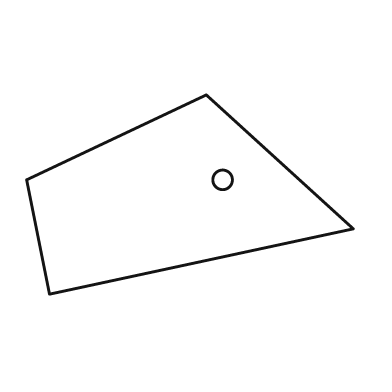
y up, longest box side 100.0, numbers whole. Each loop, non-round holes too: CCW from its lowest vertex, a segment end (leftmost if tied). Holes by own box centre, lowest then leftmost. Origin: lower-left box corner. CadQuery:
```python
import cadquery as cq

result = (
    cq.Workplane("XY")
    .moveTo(7.0, 0.0)
    .lineTo(100.0, 20.0)
    .lineTo(55.0, 61.0)
    .lineTo(0.0, 35.0)
    .close()
    .moveTo(60.0, 35.0)
    .circle(3.0)
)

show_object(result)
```